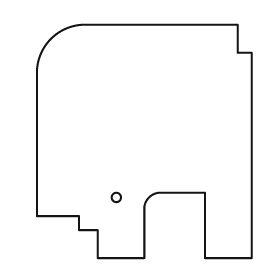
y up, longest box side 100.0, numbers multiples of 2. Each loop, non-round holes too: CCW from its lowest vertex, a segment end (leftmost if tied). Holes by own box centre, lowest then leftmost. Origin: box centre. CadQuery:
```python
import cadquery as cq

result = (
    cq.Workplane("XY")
    .moveTo(-20.0, -50.0)
    .lineTo(0.0, -50.0)
    .lineTo(0.0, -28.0)
    .threePointArc((2.0, -24.0), (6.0, -22.0))
    .lineTo(26.0, -22.0)
    .lineTo(26.0, -50.0)
    .lineTo(46.0, -50.0)
    .lineTo(46.0, 38.0)
    .lineTo(40.0, 38.0)
    .lineTo(40.0, 50.0)
    .lineTo(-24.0, 50.0)
    .threePointArc((-40.0, 44.0), (-46.0, 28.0))
    .lineTo(-46.0, -32.0)
    .lineTo(-28.0, -32.0)
    .lineTo(-28.0, -38.0)
    .lineTo(-20.0, -38.0)
    .close()
    .moveTo(-12.0, -24.0)
    .circle(2.0)
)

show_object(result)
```